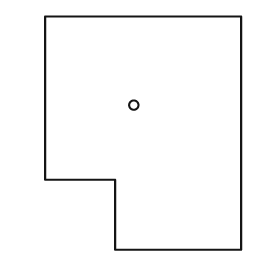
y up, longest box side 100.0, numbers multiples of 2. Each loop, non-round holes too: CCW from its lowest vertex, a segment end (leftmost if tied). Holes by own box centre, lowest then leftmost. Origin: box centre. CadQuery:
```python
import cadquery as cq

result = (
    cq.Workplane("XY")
    .moveTo(-12.0, -50.0)
    .lineTo(42.0, -50.0)
    .lineTo(42.0, 50.0)
    .lineTo(-42.0, 50.0)
    .lineTo(-42.0, -20.0)
    .lineTo(-12.0, -20.0)
    .close()
    .moveTo(-4.0, 12.0)
    .circle(2.0)
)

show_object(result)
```